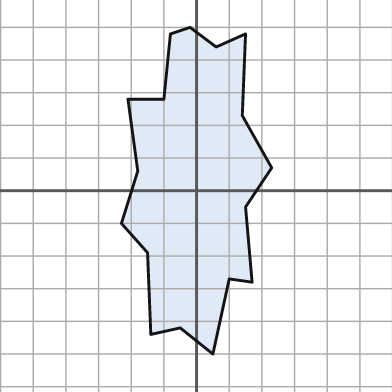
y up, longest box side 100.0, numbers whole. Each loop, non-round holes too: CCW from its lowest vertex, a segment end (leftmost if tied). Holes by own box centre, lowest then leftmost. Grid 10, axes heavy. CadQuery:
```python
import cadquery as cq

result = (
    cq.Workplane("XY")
    .moveTo(5.0, -50.0)
    .lineTo(10.0, -27.0)
    .lineTo(17.0, -28.0)
    .lineTo(15.0, -5.0)
    .lineTo(23.0, 7.0)
    .lineTo(14.0, 23.0)
    .lineTo(15.0, 48.0)
    .lineTo(6.0, 44.0)
    .lineTo(-2.0, 50.0)
    .lineTo(-8.0, 48.0)
    .lineTo(-10.0, 28.0)
    .lineTo(-21.0, 28.0)
    .lineTo(-18.0, 6.0)
    .lineTo(-23.0, -10.0)
    .lineTo(-15.0, -19.0)
    .lineTo(-14.0, -44.0)
    .lineTo(-5.0, -42.0)
    .close()
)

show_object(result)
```